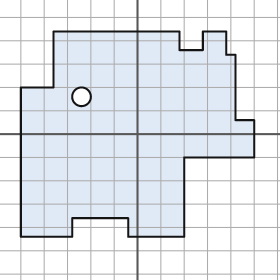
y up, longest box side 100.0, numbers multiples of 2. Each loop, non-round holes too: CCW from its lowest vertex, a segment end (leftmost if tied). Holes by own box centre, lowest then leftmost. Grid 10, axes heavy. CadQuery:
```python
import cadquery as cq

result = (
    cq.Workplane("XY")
    .moveTo(-50.0, -44.0)
    .lineTo(-28.0, -44.0)
    .lineTo(-28.0, -36.0)
    .lineTo(-4.0, -36.0)
    .lineTo(-4.0, -44.0)
    .lineTo(20.0, -44.0)
    .lineTo(20.0, -10.0)
    .lineTo(50.0, -10.0)
    .lineTo(50.0, 6.0)
    .lineTo(42.0, 6.0)
    .lineTo(42.0, 34.0)
    .lineTo(38.0, 34.0)
    .lineTo(38.0, 44.0)
    .lineTo(28.0, 44.0)
    .lineTo(28.0, 36.0)
    .lineTo(18.0, 36.0)
    .lineTo(18.0, 44.0)
    .lineTo(-36.0, 44.0)
    .lineTo(-36.0, 20.0)
    .lineTo(-50.0, 20.0)
    .close()
    .moveTo(-24.0, 16.0)
    .circle(4.0)
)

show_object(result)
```